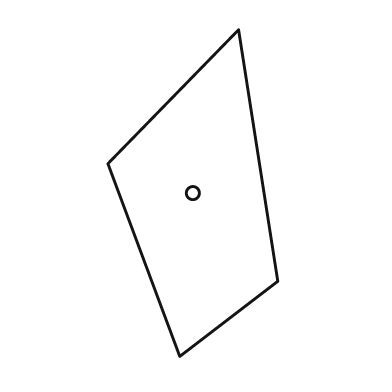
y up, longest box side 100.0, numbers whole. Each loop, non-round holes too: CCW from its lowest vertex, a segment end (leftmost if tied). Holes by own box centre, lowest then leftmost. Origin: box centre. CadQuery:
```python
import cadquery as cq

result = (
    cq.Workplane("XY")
    .moveTo(-4.0, -50.0)
    .lineTo(26.0, -27.0)
    .lineTo(14.0, 50.0)
    .lineTo(-26.0, 9.0)
    .close()
    .moveTo(0.0, 0.0)
    .circle(2.0)
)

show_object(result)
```